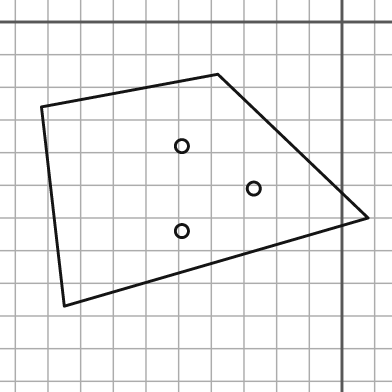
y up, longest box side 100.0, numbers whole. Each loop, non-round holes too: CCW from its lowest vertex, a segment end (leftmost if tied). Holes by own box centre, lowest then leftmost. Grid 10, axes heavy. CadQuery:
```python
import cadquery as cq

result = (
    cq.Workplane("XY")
    .moveTo(-85.0, -87.0)
    .lineTo(8.0, -60.0)
    .lineTo(-38.0, -16.0)
    .lineTo(-92.0, -26.0)
    .close()
    .moveTo(-49.0, -64.0)
    .circle(2.0)
    .moveTo(-27.0, -51.0)
    .circle(2.0)
    .moveTo(-49.0, -38.0)
    .circle(2.0)
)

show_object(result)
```